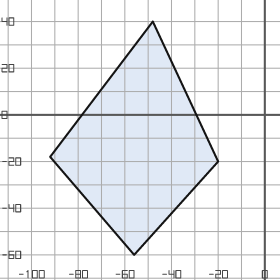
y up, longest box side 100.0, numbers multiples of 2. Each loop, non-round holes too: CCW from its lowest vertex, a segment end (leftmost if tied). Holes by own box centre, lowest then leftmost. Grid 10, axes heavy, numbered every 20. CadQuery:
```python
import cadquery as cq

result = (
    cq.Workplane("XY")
    .moveTo(-56.0, -60.0)
    .lineTo(-20.0, -20.0)
    .lineTo(-48.0, 40.0)
    .lineTo(-92.0, -18.0)
    .close()
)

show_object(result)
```